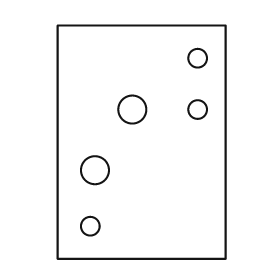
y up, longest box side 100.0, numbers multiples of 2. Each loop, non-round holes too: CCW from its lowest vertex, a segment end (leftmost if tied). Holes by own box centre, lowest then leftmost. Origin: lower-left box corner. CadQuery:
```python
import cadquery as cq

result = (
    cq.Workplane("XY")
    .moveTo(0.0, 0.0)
    .lineTo(72.0, 0.0)
    .lineTo(72.0, 100.0)
    .lineTo(0.0, 100.0)
    .close()
    .moveTo(14.0, 14.0)
    .circle(4.0)
    .moveTo(16.0, 38.0)
    .circle(6.0)
    .moveTo(32.0, 64.0)
    .circle(6.0)
    .moveTo(60.0, 64.0)
    .circle(4.0)
    .moveTo(60.0, 86.0)
    .circle(4.0)
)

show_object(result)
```